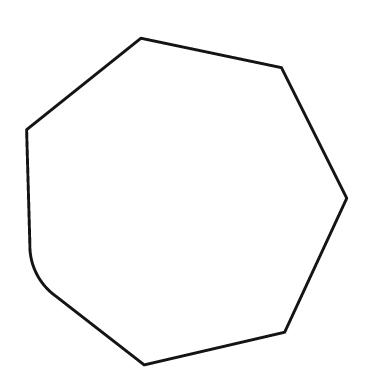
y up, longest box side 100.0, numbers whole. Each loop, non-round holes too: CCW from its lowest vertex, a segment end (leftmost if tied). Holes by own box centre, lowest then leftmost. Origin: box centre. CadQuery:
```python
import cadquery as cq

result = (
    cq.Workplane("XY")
    .moveTo(-13.0, -50.0)
    .lineTo(30.0, -40.0)
    .lineTo(49.0, 1.0)
    .lineTo(29.0, 41.0)
    .lineTo(-14.0, 50.0)
    .lineTo(-49.0, 22.0)
    .lineTo(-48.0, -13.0)
    .threePointArc((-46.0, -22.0), (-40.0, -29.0))
    .close()
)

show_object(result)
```